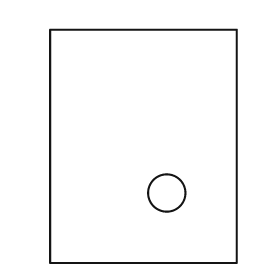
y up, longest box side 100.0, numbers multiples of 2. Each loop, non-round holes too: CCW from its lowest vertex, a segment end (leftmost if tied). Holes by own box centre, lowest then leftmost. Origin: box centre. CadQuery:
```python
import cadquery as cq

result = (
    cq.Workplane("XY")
    .moveTo(-40.0, -50.0)
    .lineTo(40.0, -50.0)
    .lineTo(40.0, 50.0)
    .lineTo(-40.0, 50.0)
    .close()
    .moveTo(10.0, -20.0)
    .circle(8.0)
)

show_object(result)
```